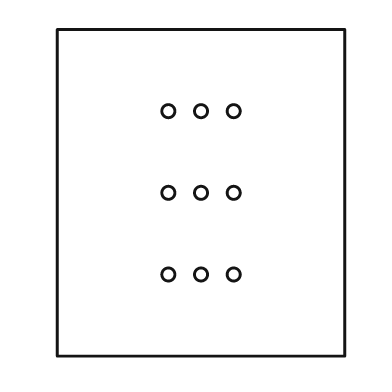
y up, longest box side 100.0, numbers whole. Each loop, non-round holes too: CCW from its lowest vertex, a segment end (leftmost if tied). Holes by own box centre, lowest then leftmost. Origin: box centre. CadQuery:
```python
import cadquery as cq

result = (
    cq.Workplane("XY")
    .moveTo(-44.0, -50.0)
    .lineTo(44.0, -50.0)
    .lineTo(44.0, 50.0)
    .lineTo(-44.0, 50.0)
    .close()
    .moveTo(-10.0, -25.0)
    .circle(2.0)
    .moveTo(0.0, -25.0)
    .circle(2.0)
    .moveTo(10.0, -25.0)
    .circle(2.0)
    .moveTo(-10.0, 0.0)
    .circle(2.0)
    .moveTo(0.0, 0.0)
    .circle(2.0)
    .moveTo(10.0, 0.0)
    .circle(2.0)
    .moveTo(-10.0, 25.0)
    .circle(2.0)
    .moveTo(0.0, 25.0)
    .circle(2.0)
    .moveTo(10.0, 25.0)
    .circle(2.0)
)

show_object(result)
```